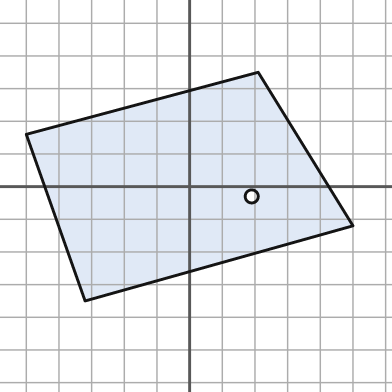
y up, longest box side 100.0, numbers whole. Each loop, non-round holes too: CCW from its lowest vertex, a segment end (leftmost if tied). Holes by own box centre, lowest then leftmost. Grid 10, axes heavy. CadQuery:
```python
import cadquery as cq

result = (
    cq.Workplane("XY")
    .moveTo(-32.0, -35.0)
    .lineTo(50.0, -12.0)
    .lineTo(21.0, 35.0)
    .lineTo(-50.0, 16.0)
    .close()
    .moveTo(19.0, -3.0)
    .circle(2.0)
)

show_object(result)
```